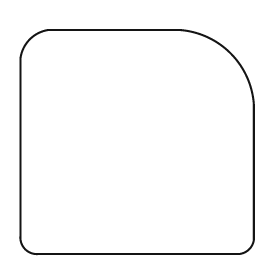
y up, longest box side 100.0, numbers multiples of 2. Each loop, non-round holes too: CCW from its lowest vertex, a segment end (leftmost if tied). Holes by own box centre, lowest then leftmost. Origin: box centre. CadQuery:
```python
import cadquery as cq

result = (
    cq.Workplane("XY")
    .moveTo(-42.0, -48.0)
    .lineTo(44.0, -48.0)
    .threePointArc((48.0, -46.0), (50.0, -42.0))
    .lineTo(50.0, 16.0)
    .threePointArc((40.0, 38.0), (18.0, 48.0))
    .lineTo(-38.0, 48.0)
    .threePointArc((-46.0, 44.0), (-50.0, 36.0))
    .lineTo(-50.0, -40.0)
    .threePointArc((-48.0, -46.0), (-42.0, -48.0))
    .close()
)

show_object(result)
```